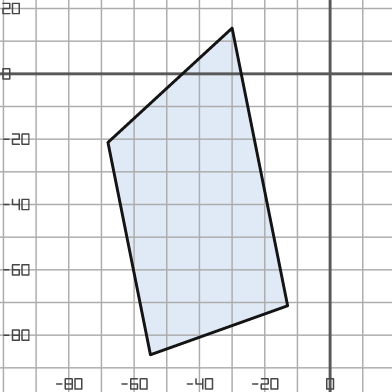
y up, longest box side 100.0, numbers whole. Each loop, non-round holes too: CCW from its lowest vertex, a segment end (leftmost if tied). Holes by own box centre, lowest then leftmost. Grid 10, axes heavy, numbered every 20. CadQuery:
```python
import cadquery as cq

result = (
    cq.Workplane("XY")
    .moveTo(-55.0, -86.0)
    .lineTo(-13.0, -71.0)
    .lineTo(-30.0, 14.0)
    .lineTo(-68.0, -21.0)
    .close()
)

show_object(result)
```